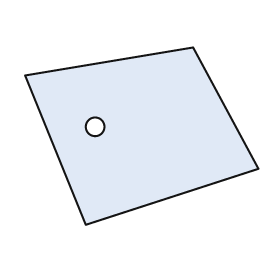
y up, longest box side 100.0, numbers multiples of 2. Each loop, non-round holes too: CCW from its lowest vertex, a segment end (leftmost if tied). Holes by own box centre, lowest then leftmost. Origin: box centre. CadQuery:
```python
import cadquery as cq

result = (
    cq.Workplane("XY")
    .moveTo(-24.0, -38.0)
    .lineTo(50.0, -14.0)
    .lineTo(22.0, 38.0)
    .lineTo(-50.0, 26.0)
    .close()
    .moveTo(-20.0, 4.0)
    .circle(4.0)
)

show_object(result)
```